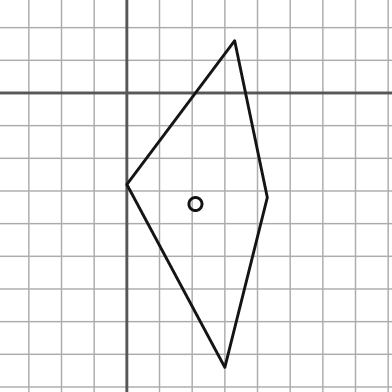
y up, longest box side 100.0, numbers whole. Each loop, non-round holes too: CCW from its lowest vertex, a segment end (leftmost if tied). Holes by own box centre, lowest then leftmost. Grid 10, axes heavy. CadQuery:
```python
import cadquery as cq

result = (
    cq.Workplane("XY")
    .moveTo(30.0, -84.0)
    .lineTo(43.0, -32.0)
    .lineTo(33.0, 16.0)
    .lineTo(0.0, -28.0)
    .close()
    .moveTo(21.0, -34.0)
    .circle(2.0)
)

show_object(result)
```